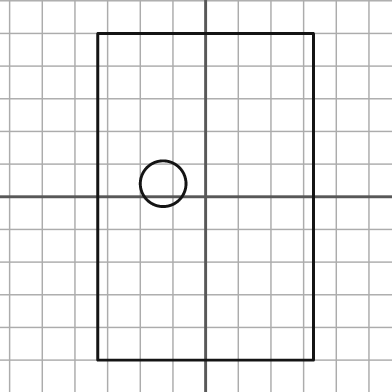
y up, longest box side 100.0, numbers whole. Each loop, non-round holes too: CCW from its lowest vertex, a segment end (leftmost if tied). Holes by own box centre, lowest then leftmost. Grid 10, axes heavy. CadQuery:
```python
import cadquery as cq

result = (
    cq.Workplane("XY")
    .moveTo(-33.0, -50.0)
    .lineTo(33.0, -50.0)
    .lineTo(33.0, 50.0)
    .lineTo(-33.0, 50.0)
    .close()
    .moveTo(-13.0, 4.0)
    .circle(7.0)
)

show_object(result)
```